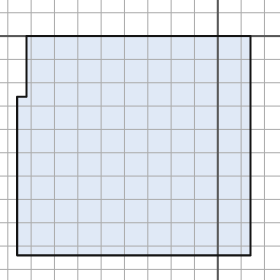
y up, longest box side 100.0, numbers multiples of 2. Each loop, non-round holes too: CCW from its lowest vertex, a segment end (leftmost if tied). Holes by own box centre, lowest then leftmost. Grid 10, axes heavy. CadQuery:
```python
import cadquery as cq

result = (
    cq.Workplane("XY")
    .moveTo(-86.0, -94.0)
    .lineTo(14.0, -94.0)
    .lineTo(14.0, 0.0)
    .lineTo(-82.0, 0.0)
    .lineTo(-82.0, -26.0)
    .lineTo(-86.0, -26.0)
    .close()
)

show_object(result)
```